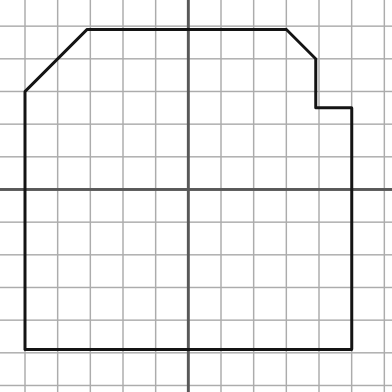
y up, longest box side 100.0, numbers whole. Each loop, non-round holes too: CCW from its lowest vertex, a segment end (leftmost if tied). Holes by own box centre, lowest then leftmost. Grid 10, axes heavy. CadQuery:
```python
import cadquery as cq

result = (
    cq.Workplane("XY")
    .moveTo(-50.0, -49.0)
    .lineTo(50.0, -49.0)
    .lineTo(50.0, 25.0)
    .lineTo(39.0, 25.0)
    .lineTo(39.0, 40.0)
    .lineTo(30.0, 49.0)
    .lineTo(-31.0, 49.0)
    .lineTo(-50.0, 30.0)
    .close()
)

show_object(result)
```